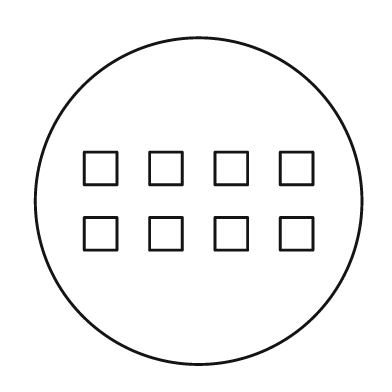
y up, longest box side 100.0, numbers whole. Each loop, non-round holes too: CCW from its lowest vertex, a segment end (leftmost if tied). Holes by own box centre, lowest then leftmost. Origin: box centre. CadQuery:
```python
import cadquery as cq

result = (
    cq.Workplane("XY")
    .moveTo(0.0, 0.0)
    .circle(50.0)
    .moveTo(-35.0, -15.0)
    .lineTo(-25.0, -15.0)
    .lineTo(-25.0, -5.0)
    .lineTo(-35.0, -5.0)
    .close()
    .moveTo(-15.0, -15.0)
    .lineTo(-5.0, -15.0)
    .lineTo(-5.0, -5.0)
    .lineTo(-15.0, -5.0)
    .close()
    .moveTo(5.0, -15.0)
    .lineTo(15.0, -15.0)
    .lineTo(15.0, -5.0)
    .lineTo(5.0, -5.0)
    .close()
    .moveTo(25.0, -15.0)
    .lineTo(35.0, -15.0)
    .lineTo(35.0, -5.0)
    .lineTo(25.0, -5.0)
    .close()
    .moveTo(-35.0, 5.0)
    .lineTo(-25.0, 5.0)
    .lineTo(-25.0, 15.0)
    .lineTo(-35.0, 15.0)
    .close()
    .moveTo(-15.0, 5.0)
    .lineTo(-5.0, 5.0)
    .lineTo(-5.0, 15.0)
    .lineTo(-15.0, 15.0)
    .close()
    .moveTo(5.0, 5.0)
    .lineTo(15.0, 5.0)
    .lineTo(15.0, 15.0)
    .lineTo(5.0, 15.0)
    .close()
    .moveTo(25.0, 5.0)
    .lineTo(35.0, 5.0)
    .lineTo(35.0, 15.0)
    .lineTo(25.0, 15.0)
    .close()
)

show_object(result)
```